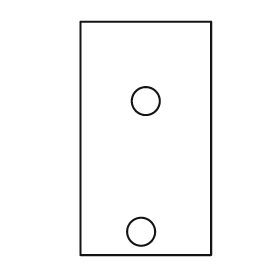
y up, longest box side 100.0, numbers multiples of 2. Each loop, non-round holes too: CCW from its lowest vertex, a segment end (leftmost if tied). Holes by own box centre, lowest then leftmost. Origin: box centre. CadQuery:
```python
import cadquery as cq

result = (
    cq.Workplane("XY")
    .moveTo(-28.0, -50.0)
    .lineTo(28.0, -50.0)
    .lineTo(28.0, 50.0)
    .lineTo(-28.0, 50.0)
    .close()
    .moveTo(-2.0, -40.0)
    .circle(6.0)
    .moveTo(0.0, 16.0)
    .circle(6.0)
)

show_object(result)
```